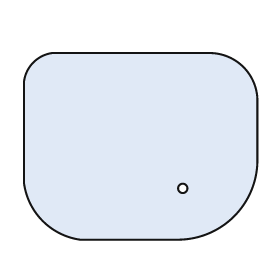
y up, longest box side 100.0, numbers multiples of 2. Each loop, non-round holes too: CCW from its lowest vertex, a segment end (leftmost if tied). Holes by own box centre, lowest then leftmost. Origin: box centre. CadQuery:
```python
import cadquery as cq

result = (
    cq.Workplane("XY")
    .moveTo(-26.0, -40.0)
    .lineTo(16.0, -40.0)
    .threePointArc((40.0, -30.0), (50.0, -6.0))
    .lineTo(50.0, 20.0)
    .threePointArc((44.0, 34.0), (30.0, 40.0))
    .lineTo(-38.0, 40.0)
    .threePointArc((-46.0, 36.0), (-50.0, 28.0))
    .lineTo(-50.0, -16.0)
    .threePointArc((-42.0, -32.0), (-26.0, -40.0))
    .close()
    .moveTo(18.0, -18.0)
    .circle(2.0)
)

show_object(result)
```